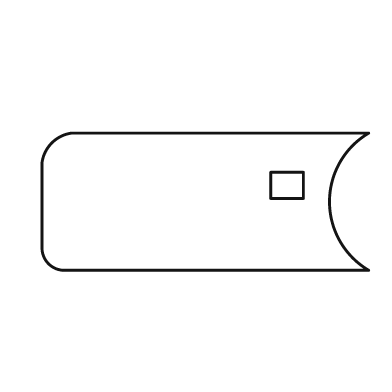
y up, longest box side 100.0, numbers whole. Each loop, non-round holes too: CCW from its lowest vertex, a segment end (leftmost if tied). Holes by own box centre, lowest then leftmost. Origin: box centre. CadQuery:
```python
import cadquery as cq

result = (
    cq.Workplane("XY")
    .moveTo(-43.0, -21.0)
    .lineTo(50.0, -21.0)
    .threePointArc((38.0, 0.0), (50.0, 21.0))
    .lineTo(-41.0, 21.0)
    .threePointArc((-47.0, 18.0), (-50.0, 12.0))
    .lineTo(-50.0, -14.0)
    .threePointArc((-48.0, -19.0), (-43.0, -21.0))
    .close()
    .moveTo(20.0, 1.0)
    .lineTo(30.0, 1.0)
    .lineTo(30.0, 9.0)
    .lineTo(20.0, 9.0)
    .close()
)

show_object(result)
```